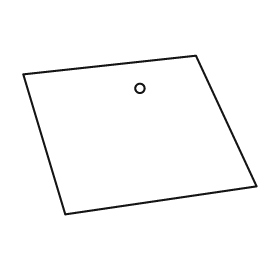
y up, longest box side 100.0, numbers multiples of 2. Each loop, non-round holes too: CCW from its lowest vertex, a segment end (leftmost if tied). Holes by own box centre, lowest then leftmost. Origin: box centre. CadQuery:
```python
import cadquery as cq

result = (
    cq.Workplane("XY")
    .moveTo(-32.0, -34.0)
    .lineTo(50.0, -22.0)
    .lineTo(24.0, 34.0)
    .lineTo(-50.0, 26.0)
    .close()
    .moveTo(0.0, 20.0)
    .circle(2.0)
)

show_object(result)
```